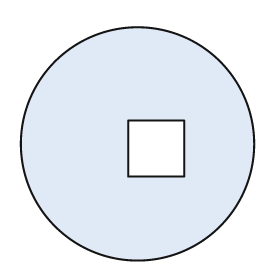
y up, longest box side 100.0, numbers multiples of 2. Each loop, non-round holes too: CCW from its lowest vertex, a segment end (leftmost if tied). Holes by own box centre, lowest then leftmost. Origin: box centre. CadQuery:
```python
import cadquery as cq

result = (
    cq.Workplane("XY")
    .moveTo(0.0, 0.0)
    .circle(50.0)
    .moveTo(-4.0, -14.0)
    .lineTo(20.0, -14.0)
    .lineTo(20.0, 10.0)
    .lineTo(-4.0, 10.0)
    .close()
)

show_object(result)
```